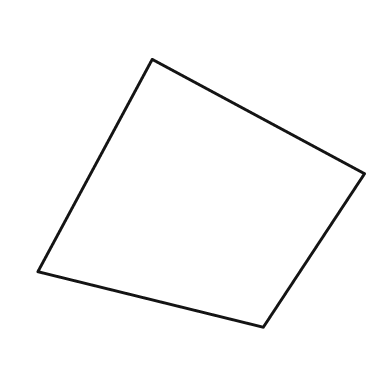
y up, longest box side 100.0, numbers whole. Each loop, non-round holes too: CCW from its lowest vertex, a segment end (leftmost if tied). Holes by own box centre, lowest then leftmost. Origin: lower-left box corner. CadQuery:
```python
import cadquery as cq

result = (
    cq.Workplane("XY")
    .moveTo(69.0, 0.0)
    .lineTo(100.0, 47.0)
    .lineTo(35.0, 82.0)
    .lineTo(0.0, 17.0)
    .close()
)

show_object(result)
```